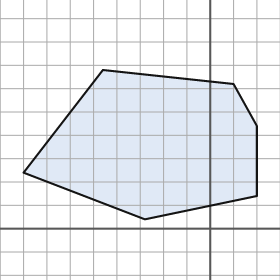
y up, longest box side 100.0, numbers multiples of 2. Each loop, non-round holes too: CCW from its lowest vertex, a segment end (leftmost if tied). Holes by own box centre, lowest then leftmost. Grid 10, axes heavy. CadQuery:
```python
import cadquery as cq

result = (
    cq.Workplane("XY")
    .moveTo(-28.0, 4.0)
    .lineTo(20.0, 14.0)
    .lineTo(20.0, 44.0)
    .lineTo(10.0, 62.0)
    .lineTo(-46.0, 68.0)
    .lineTo(-80.0, 24.0)
    .close()
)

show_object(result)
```